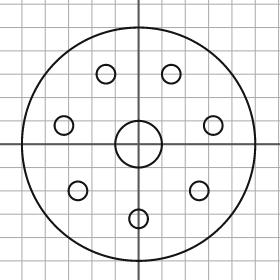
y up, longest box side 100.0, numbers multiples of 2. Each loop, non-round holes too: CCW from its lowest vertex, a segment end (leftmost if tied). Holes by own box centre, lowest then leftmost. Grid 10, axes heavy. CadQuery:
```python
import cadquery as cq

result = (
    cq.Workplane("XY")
    .moveTo(0.0, 0.0)
    .circle(50.0)
    .moveTo(0.0, -32.0)
    .circle(4.0)
    .moveTo(-26.0, -20.0)
    .circle(4.0)
    .moveTo(26.0, -20.0)
    .circle(4.0)
    .moveTo(0.0, 0.0)
    .circle(10.0)
    .moveTo(-32.0, 8.0)
    .circle(4.0)
    .moveTo(32.0, 8.0)
    .circle(4.0)
    .moveTo(-14.0, 30.0)
    .circle(4.0)
    .moveTo(14.0, 30.0)
    .circle(4.0)
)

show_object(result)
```